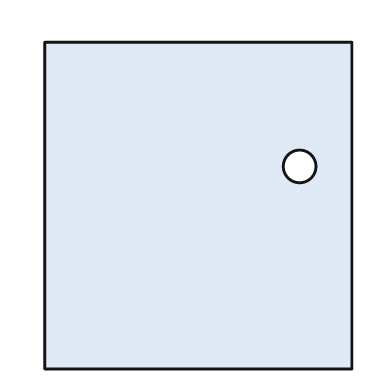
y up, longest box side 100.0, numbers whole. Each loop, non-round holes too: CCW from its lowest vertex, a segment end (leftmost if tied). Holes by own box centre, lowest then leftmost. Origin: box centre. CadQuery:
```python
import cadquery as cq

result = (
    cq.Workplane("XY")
    .moveTo(-47.0, -50.0)
    .lineTo(47.0, -50.0)
    .lineTo(47.0, 50.0)
    .lineTo(-47.0, 50.0)
    .close()
    .moveTo(31.0, 12.0)
    .circle(5.0)
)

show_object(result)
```